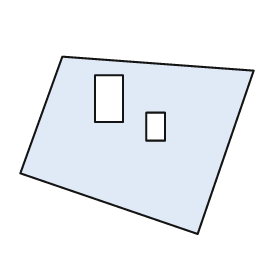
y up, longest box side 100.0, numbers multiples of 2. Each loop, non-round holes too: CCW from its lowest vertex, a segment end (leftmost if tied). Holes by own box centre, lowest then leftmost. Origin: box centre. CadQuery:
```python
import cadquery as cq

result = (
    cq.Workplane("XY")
    .moveTo(26.0, -38.0)
    .lineTo(50.0, 32.0)
    .lineTo(-32.0, 38.0)
    .lineTo(-50.0, -12.0)
    .close()
    .moveTo(4.0, 2.0)
    .lineTo(12.0, 2.0)
    .lineTo(12.0, 14.0)
    .lineTo(4.0, 14.0)
    .close()
    .moveTo(-18.0, 10.0)
    .lineTo(-6.0, 10.0)
    .lineTo(-6.0, 30.0)
    .lineTo(-18.0, 30.0)
    .close()
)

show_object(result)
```